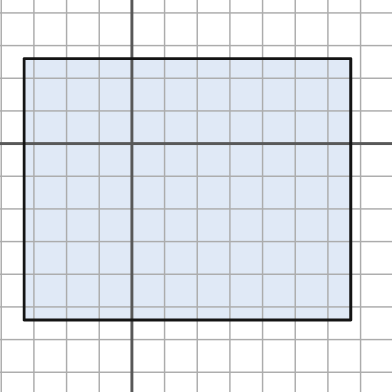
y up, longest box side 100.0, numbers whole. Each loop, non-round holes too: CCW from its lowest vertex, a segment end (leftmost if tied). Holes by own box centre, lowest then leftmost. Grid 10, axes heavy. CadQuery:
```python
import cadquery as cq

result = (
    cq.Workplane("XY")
    .moveTo(-33.0, -54.0)
    .lineTo(67.0, -54.0)
    .lineTo(67.0, 26.0)
    .lineTo(-33.0, 26.0)
    .close()
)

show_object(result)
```